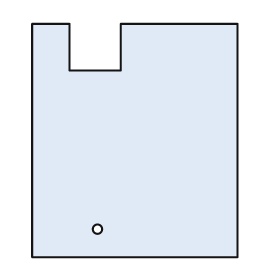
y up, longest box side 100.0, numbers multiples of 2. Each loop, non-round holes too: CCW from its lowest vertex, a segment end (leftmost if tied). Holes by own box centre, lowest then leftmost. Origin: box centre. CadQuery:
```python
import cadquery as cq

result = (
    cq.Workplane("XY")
    .moveTo(-44.0, -50.0)
    .lineTo(44.0, -50.0)
    .lineTo(44.0, 50.0)
    .lineTo(-6.0, 50.0)
    .lineTo(-6.0, 30.0)
    .lineTo(-28.0, 30.0)
    .lineTo(-28.0, 50.0)
    .lineTo(-44.0, 50.0)
    .close()
    .moveTo(-16.0, -38.0)
    .circle(2.0)
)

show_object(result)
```